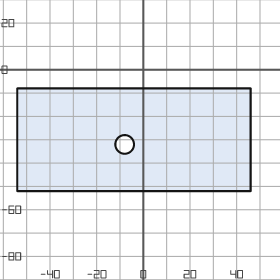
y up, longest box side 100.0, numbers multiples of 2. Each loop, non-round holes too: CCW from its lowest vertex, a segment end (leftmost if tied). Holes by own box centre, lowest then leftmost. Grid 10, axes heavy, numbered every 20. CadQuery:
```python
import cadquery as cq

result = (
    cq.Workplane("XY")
    .moveTo(-54.0, -52.0)
    .lineTo(46.0, -52.0)
    .lineTo(46.0, -8.0)
    .lineTo(-54.0, -8.0)
    .close()
    .moveTo(-8.0, -32.0)
    .circle(4.0)
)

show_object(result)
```